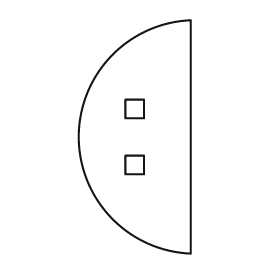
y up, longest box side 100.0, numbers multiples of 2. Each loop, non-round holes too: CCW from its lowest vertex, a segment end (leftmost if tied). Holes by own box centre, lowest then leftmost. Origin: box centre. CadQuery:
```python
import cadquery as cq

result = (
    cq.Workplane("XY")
    .moveTo(24.0, -50.0)
    .lineTo(24.0, 50.0)
    .threePointArc((-24.0, 0.0), (24.0, -50.0))
    .close()
    .moveTo(-4.0, -16.0)
    .lineTo(4.0, -16.0)
    .lineTo(4.0, -8.0)
    .lineTo(-4.0, -8.0)
    .close()
    .moveTo(-4.0, 8.0)
    .lineTo(4.0, 8.0)
    .lineTo(4.0, 16.0)
    .lineTo(-4.0, 16.0)
    .close()
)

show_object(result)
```